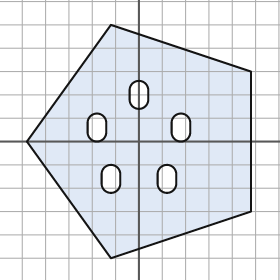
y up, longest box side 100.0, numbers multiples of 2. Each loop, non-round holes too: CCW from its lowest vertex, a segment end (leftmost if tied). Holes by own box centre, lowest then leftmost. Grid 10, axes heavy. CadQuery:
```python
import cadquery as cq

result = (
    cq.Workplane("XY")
    .moveTo(-12.0, -50.0)
    .lineTo(48.0, -30.0)
    .lineTo(48.0, 30.0)
    .lineTo(-12.0, 50.0)
    .lineTo(-48.0, 0.0)
    .close()
    .moveTo(-16.0, -18.0)
    .threePointArc((-12.0, -22.0), (-8.0, -18.0))
    .lineTo(-8.0, -14.0)
    .threePointArc((-12.0, -10.0), (-16.0, -14.0))
    .close()
    .moveTo(8.0, -18.0)
    .threePointArc((12.0, -22.0), (16.0, -18.0))
    .lineTo(16.0, -14.0)
    .threePointArc((12.0, -10.0), (8.0, -14.0))
    .close()
    .moveTo(-22.0, 4.0)
    .threePointArc((-18.0, 0.0), (-14.0, 4.0))
    .lineTo(-14.0, 8.0)
    .threePointArc((-18.0, 12.0), (-22.0, 8.0))
    .close()
    .moveTo(14.0, 4.0)
    .threePointArc((18.0, 0.0), (22.0, 4.0))
    .lineTo(22.0, 8.0)
    .threePointArc((18.0, 12.0), (14.0, 8.0))
    .close()
    .moveTo(-4.0, 18.0)
    .threePointArc((0.0, 14.0), (4.0, 18.0))
    .lineTo(4.0, 22.0)
    .threePointArc((0.0, 26.0), (-4.0, 22.0))
    .close()
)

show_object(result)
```